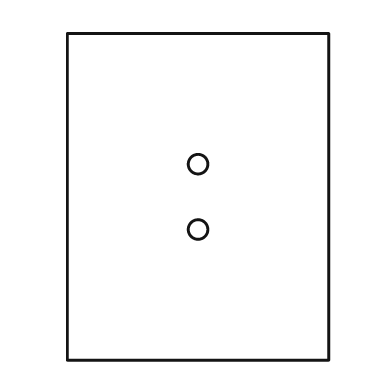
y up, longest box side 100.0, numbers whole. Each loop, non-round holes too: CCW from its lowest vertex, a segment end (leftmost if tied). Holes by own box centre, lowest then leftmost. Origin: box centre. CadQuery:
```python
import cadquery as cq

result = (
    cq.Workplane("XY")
    .moveTo(-40.0, -50.0)
    .lineTo(40.0, -50.0)
    .lineTo(40.0, 50.0)
    .lineTo(-40.0, 50.0)
    .close()
    .moveTo(0.0, -10.0)
    .circle(3.0)
    .moveTo(0.0, 10.0)
    .circle(3.0)
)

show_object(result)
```